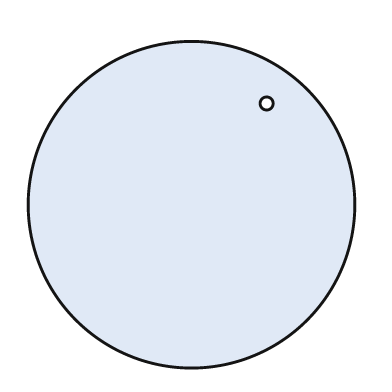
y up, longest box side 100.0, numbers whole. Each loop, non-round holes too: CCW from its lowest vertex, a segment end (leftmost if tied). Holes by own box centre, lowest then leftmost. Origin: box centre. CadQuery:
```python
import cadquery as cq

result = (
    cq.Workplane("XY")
    .moveTo(0.0, 0.0)
    .circle(50.0)
    .moveTo(23.0, 31.0)
    .circle(2.0)
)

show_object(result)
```